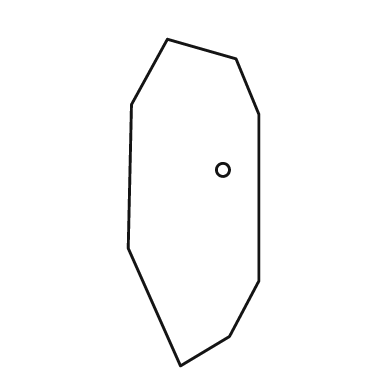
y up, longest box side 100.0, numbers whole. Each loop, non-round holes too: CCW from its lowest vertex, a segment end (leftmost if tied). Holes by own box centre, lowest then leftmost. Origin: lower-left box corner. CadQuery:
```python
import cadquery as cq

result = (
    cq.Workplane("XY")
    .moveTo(16.0, 0.0)
    .lineTo(31.0, 9.0)
    .lineTo(40.0, 26.0)
    .lineTo(40.0, 77.0)
    .lineTo(33.0, 94.0)
    .lineTo(12.0, 100.0)
    .lineTo(1.0, 80.0)
    .lineTo(0.0, 36.0)
    .close()
    .moveTo(29.0, 60.0)
    .circle(2.0)
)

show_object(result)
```